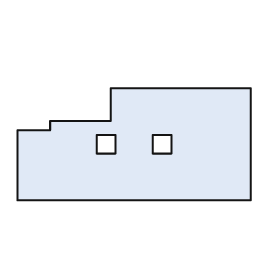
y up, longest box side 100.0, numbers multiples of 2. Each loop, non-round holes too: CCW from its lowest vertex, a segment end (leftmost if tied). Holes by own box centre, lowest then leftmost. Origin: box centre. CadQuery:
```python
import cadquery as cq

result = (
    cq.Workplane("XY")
    .moveTo(-50.0, -24.0)
    .lineTo(50.0, -24.0)
    .lineTo(50.0, 24.0)
    .lineTo(-10.0, 24.0)
    .lineTo(-10.0, 10.0)
    .lineTo(-36.0, 10.0)
    .lineTo(-36.0, 6.0)
    .lineTo(-50.0, 6.0)
    .close()
    .moveTo(-16.0, -4.0)
    .lineTo(-8.0, -4.0)
    .lineTo(-8.0, 4.0)
    .lineTo(-16.0, 4.0)
    .close()
    .moveTo(8.0, -4.0)
    .lineTo(16.0, -4.0)
    .lineTo(16.0, 4.0)
    .lineTo(8.0, 4.0)
    .close()
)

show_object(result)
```